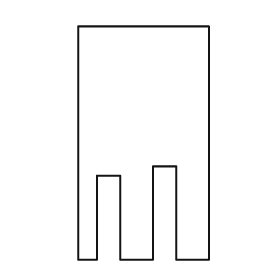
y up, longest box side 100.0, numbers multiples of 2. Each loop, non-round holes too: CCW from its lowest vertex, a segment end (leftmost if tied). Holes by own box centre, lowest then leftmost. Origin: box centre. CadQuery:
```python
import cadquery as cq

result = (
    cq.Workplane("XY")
    .moveTo(-28.0, -50.0)
    .lineTo(-20.0, -50.0)
    .lineTo(-20.0, -14.0)
    .lineTo(-10.0, -14.0)
    .lineTo(-10.0, -50.0)
    .lineTo(4.0, -50.0)
    .lineTo(4.0, -10.0)
    .lineTo(14.0, -10.0)
    .lineTo(14.0, -50.0)
    .lineTo(28.0, -50.0)
    .lineTo(28.0, 50.0)
    .lineTo(-28.0, 50.0)
    .close()
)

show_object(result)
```